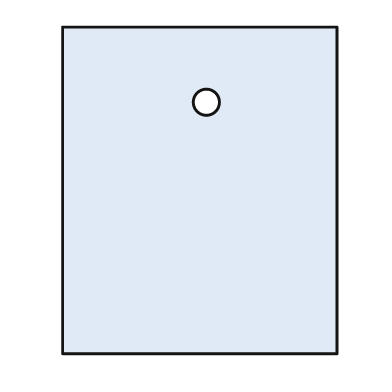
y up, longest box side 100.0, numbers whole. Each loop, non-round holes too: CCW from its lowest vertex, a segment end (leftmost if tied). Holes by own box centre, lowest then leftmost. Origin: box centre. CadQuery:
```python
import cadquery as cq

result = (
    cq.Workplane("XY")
    .moveTo(-42.0, -50.0)
    .lineTo(42.0, -50.0)
    .lineTo(42.0, 50.0)
    .lineTo(-42.0, 50.0)
    .close()
    .moveTo(2.0, 27.0)
    .circle(4.0)
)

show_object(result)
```